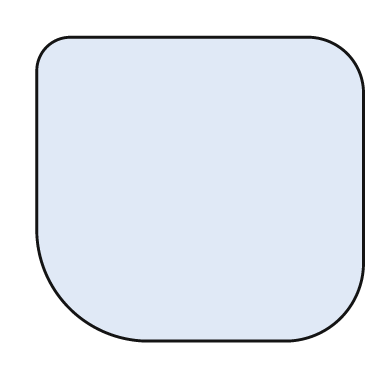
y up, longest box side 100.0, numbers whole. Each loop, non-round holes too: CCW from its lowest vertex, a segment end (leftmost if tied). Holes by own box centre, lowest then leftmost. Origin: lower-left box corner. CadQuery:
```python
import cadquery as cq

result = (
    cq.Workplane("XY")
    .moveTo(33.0, 0.0)
    .lineTo(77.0, 0.0)
    .threePointArc((93.0, 7.0), (100.0, 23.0))
    .lineTo(100.0, 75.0)
    .threePointArc((95.0, 88.0), (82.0, 93.0))
    .lineTo(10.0, 93.0)
    .threePointArc((3.0, 90.0), (0.0, 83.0))
    .lineTo(0.0, 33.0)
    .threePointArc((10.0, 10.0), (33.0, 0.0))
    .close()
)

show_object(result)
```